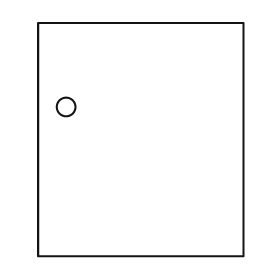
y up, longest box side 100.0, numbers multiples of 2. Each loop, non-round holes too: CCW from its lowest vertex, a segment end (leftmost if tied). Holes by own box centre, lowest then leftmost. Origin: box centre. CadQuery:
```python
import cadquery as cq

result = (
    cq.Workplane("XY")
    .moveTo(-44.0, -50.0)
    .lineTo(44.0, -50.0)
    .lineTo(44.0, 50.0)
    .lineTo(-44.0, 50.0)
    .close()
    .moveTo(-32.0, 14.0)
    .circle(4.0)
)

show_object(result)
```